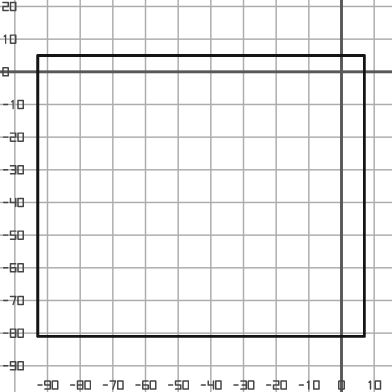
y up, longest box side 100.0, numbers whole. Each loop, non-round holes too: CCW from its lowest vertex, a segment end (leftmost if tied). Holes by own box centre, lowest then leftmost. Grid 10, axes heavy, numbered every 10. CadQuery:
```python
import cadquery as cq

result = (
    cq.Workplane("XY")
    .moveTo(-93.0, -81.0)
    .lineTo(7.0, -81.0)
    .lineTo(7.0, 5.0)
    .lineTo(-93.0, 5.0)
    .close()
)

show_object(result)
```